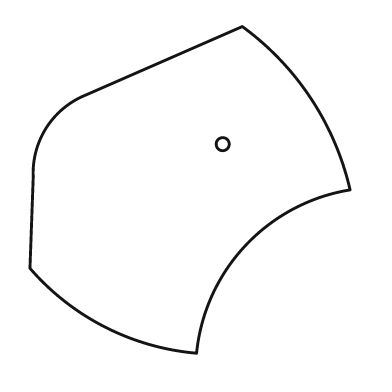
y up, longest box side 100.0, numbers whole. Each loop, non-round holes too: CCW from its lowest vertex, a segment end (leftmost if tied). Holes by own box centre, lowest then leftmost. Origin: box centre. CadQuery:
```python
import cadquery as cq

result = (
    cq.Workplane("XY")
    .moveTo(2.0, -50.0)
    .threePointArc((17.0, -17.0), (49.0, 0.0))
    .threePointArc((37.0, 28.0), (16.0, 50.0))
    .lineTo(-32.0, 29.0)
    .threePointArc((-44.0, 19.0), (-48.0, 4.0))
    .lineTo(-49.0, -24.0)
    .threePointArc((-26.0, -42.0), (2.0, -50.0))
    .close()
    .moveTo(10.0, 14.0)
    .circle(2.0)
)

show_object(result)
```